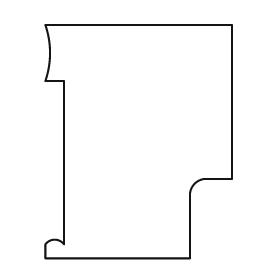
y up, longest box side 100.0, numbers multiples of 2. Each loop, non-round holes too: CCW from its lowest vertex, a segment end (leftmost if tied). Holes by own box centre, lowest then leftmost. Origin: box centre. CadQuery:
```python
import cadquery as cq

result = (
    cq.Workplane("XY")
    .moveTo(-40.0, -50.0)
    .lineTo(22.0, -50.0)
    .lineTo(22.0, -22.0)
    .threePointArc((24.0, -18.0), (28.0, -16.0))
    .lineTo(40.0, -16.0)
    .lineTo(40.0, 50.0)
    .lineTo(-40.0, 50.0)
    .threePointArc((-38.0, 38.0), (-40.0, 26.0))
    .lineTo(-32.0, 26.0)
    .lineTo(-32.0, -44.0)
    .threePointArc((-36.0, -42.0), (-40.0, -44.0))
    .close()
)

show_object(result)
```